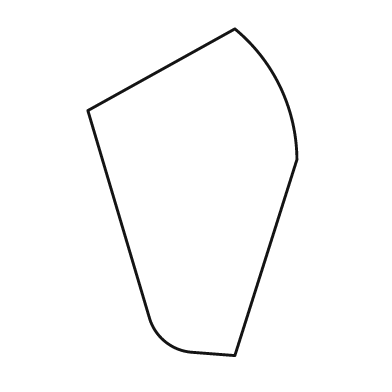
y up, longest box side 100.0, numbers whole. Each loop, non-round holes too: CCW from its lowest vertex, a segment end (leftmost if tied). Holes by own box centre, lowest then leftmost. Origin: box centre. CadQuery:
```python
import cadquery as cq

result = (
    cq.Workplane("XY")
    .moveTo(13.0, -50.0)
    .lineTo(32.0, 10.0)
    .threePointArc((27.0, 32.0), (13.0, 50.0))
    .lineTo(-32.0, 25.0)
    .lineTo(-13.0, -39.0)
    .threePointArc((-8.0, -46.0), (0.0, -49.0))
    .close()
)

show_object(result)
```